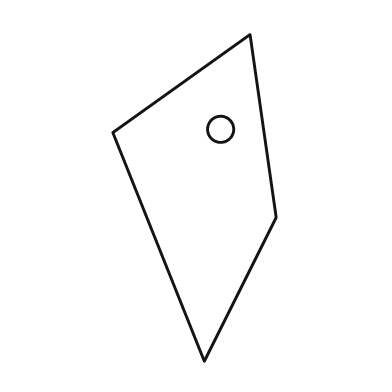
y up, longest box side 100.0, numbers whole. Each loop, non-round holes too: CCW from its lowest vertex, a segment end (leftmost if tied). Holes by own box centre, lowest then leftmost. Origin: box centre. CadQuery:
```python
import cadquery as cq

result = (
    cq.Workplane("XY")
    .moveTo(3.0, -50.0)
    .lineTo(25.0, -6.0)
    .lineTo(17.0, 50.0)
    .lineTo(-25.0, 20.0)
    .close()
    .moveTo(8.0, 21.0)
    .circle(4.0)
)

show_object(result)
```